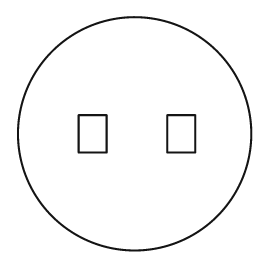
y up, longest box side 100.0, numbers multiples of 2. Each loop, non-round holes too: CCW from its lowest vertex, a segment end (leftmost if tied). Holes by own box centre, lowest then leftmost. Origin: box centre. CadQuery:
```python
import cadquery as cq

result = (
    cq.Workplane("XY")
    .moveTo(0.0, 0.0)
    .circle(50.0)
    .moveTo(-24.0, -8.0)
    .lineTo(-12.0, -8.0)
    .lineTo(-12.0, 8.0)
    .lineTo(-24.0, 8.0)
    .close()
    .moveTo(14.0, -8.0)
    .lineTo(26.0, -8.0)
    .lineTo(26.0, 8.0)
    .lineTo(14.0, 8.0)
    .close()
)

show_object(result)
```